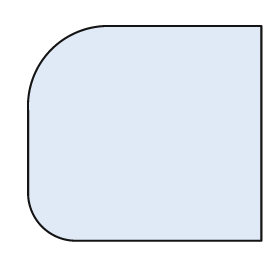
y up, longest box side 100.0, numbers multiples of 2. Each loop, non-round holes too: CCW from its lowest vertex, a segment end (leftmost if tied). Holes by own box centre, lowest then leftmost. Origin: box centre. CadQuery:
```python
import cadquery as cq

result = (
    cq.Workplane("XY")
    .moveTo(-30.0, -46.0)
    .lineTo(50.0, -46.0)
    .lineTo(50.0, 46.0)
    .lineTo(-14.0, 46.0)
    .threePointArc((-40.0, 36.0), (-50.0, 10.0))
    .lineTo(-50.0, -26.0)
    .threePointArc((-44.0, -40.0), (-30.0, -46.0))
    .close()
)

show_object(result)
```